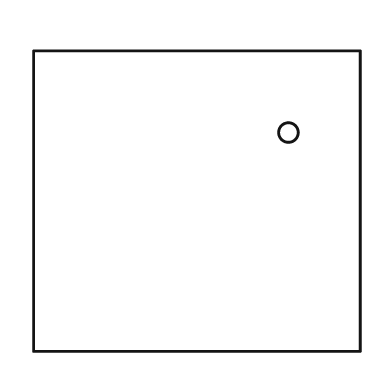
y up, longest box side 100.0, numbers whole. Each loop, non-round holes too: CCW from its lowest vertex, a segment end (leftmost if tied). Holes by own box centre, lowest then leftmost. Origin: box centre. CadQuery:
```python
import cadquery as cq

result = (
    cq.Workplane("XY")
    .moveTo(-50.0, -46.0)
    .lineTo(50.0, -46.0)
    .lineTo(50.0, 46.0)
    .lineTo(-50.0, 46.0)
    .close()
    .moveTo(28.0, 21.0)
    .circle(3.0)
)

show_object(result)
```